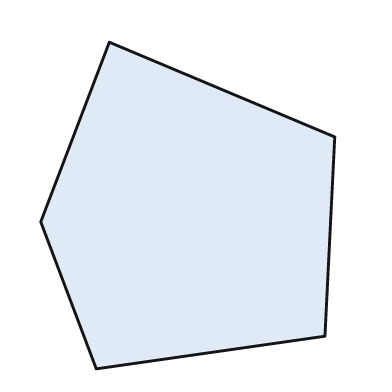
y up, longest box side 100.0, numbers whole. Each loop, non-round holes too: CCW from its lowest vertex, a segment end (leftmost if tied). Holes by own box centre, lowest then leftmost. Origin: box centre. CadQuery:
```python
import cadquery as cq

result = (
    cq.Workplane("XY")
    .moveTo(-28.0, -50.0)
    .lineTo(42.0, -40.0)
    .lineTo(45.0, 21.0)
    .lineTo(-24.0, 50.0)
    .lineTo(-45.0, -5.0)
    .close()
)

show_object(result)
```